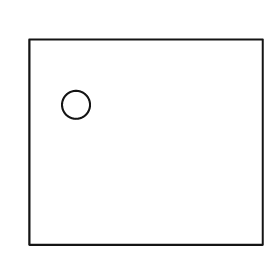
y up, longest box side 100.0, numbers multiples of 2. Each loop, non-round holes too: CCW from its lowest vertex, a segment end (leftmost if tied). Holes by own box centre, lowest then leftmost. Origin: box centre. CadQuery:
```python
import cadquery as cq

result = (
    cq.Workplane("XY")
    .moveTo(-50.0, -44.0)
    .lineTo(50.0, -44.0)
    .lineTo(50.0, 44.0)
    .lineTo(-50.0, 44.0)
    .close()
    .moveTo(-30.0, 16.0)
    .circle(6.0)
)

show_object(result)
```